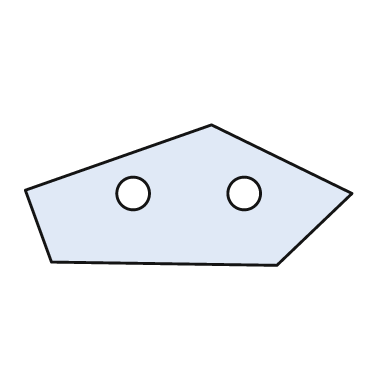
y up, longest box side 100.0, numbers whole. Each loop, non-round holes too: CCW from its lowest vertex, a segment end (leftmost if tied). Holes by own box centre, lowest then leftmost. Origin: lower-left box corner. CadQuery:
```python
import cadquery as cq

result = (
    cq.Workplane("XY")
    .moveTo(77.0, 0.0)
    .lineTo(100.0, 22.0)
    .lineTo(57.0, 43.0)
    .lineTo(0.0, 23.0)
    .lineTo(8.0, 1.0)
    .close()
    .moveTo(33.0, 22.0)
    .circle(5.0)
    .moveTo(67.0, 22.0)
    .circle(5.0)
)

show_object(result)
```